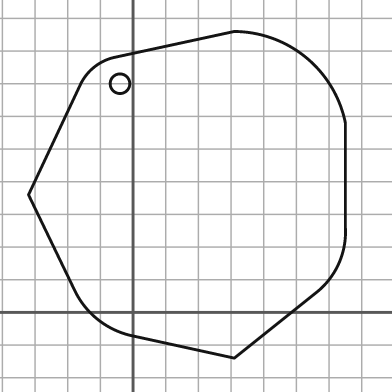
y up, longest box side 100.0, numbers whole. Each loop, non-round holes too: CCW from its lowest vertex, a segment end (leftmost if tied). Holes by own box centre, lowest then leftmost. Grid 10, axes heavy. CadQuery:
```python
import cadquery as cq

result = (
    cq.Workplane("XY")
    .moveTo(31.0, -14.0)
    .lineTo(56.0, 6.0)
    .threePointArc((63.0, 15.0), (65.0, 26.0))
    .lineTo(65.0, 58.0)
    .threePointArc((53.0, 78.0), (31.0, 86.0))
    .lineTo(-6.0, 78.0)
    .threePointArc((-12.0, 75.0), (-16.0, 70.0))
    .lineTo(-32.0, 36.0)
    .lineTo(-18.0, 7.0)
    .threePointArc((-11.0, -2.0), (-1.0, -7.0))
    .close()
    .moveTo(-4.0, 70.0)
    .circle(3.0)
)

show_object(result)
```